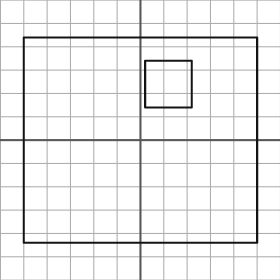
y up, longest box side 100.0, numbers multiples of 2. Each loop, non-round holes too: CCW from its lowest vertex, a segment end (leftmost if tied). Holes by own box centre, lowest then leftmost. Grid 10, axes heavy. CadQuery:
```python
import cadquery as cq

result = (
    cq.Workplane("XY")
    .moveTo(-50.0, -44.0)
    .lineTo(50.0, -44.0)
    .lineTo(50.0, 44.0)
    .lineTo(-50.0, 44.0)
    .close()
    .moveTo(2.0, 14.0)
    .lineTo(22.0, 14.0)
    .lineTo(22.0, 34.0)
    .lineTo(2.0, 34.0)
    .close()
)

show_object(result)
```